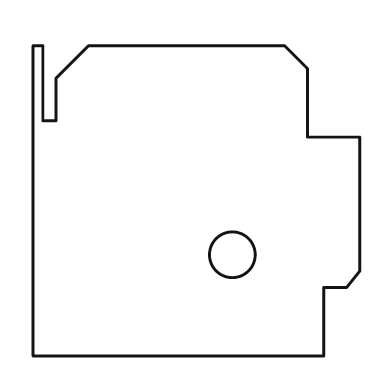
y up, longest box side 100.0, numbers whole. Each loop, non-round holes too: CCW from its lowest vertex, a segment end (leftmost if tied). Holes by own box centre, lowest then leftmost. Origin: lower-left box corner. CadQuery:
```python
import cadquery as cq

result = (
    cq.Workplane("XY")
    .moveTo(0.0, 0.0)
    .lineTo(89.0, 0.0)
    .lineTo(89.0, 21.0)
    .lineTo(96.0, 21.0)
    .lineTo(100.0, 26.0)
    .lineTo(100.0, 67.0)
    .lineTo(84.0, 67.0)
    .lineTo(84.0, 88.0)
    .lineTo(77.0, 95.0)
    .lineTo(17.0, 95.0)
    .lineTo(7.0, 85.0)
    .lineTo(7.0, 72.0)
    .lineTo(3.0, 72.0)
    .lineTo(3.0, 95.0)
    .lineTo(0.0, 95.0)
    .close()
    .moveTo(61.0, 31.0)
    .circle(7.0)
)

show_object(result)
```